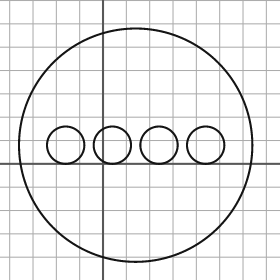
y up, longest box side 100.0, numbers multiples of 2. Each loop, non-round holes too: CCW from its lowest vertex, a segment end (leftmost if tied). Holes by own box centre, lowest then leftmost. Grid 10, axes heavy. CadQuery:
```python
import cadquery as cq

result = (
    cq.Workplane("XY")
    .moveTo(14.0, 8.0)
    .circle(50.0)
    .moveTo(-16.0, 8.0)
    .circle(8.0)
    .moveTo(4.0, 8.0)
    .circle(8.0)
    .moveTo(24.0, 8.0)
    .circle(8.0)
    .moveTo(44.0, 8.0)
    .circle(8.0)
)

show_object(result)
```